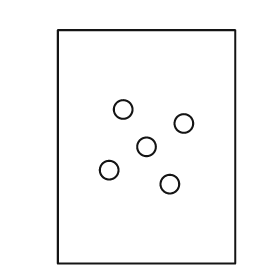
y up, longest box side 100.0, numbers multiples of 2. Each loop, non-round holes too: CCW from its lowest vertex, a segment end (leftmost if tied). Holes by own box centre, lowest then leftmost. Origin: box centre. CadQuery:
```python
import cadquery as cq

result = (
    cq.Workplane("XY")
    .moveTo(-38.0, -50.0)
    .lineTo(38.0, -50.0)
    .lineTo(38.0, 50.0)
    .lineTo(-38.0, 50.0)
    .close()
    .moveTo(10.0, -16.0)
    .circle(4.0)
    .moveTo(-16.0, -10.0)
    .circle(4.0)
    .moveTo(0.0, 0.0)
    .circle(4.0)
    .moveTo(16.0, 10.0)
    .circle(4.0)
    .moveTo(-10.0, 16.0)
    .circle(4.0)
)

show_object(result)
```